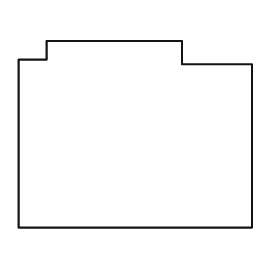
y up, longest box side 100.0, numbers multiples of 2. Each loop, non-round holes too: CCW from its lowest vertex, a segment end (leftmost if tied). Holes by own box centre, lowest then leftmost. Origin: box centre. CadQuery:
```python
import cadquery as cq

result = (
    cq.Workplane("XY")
    .moveTo(-50.0, -40.0)
    .lineTo(50.0, -40.0)
    .lineTo(50.0, 30.0)
    .lineTo(20.0, 30.0)
    .lineTo(20.0, 40.0)
    .lineTo(-38.0, 40.0)
    .lineTo(-38.0, 32.0)
    .lineTo(-50.0, 32.0)
    .close()
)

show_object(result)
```